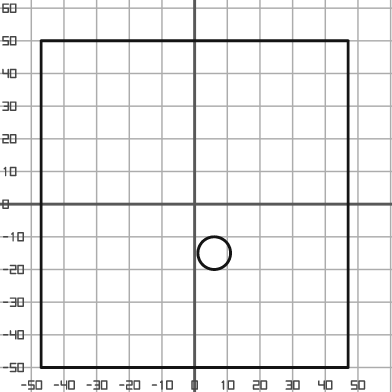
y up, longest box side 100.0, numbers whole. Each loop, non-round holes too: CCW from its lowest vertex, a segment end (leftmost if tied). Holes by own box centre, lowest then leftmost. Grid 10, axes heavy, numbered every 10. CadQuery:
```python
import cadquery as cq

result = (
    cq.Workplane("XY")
    .moveTo(-47.0, -50.0)
    .lineTo(47.0, -50.0)
    .lineTo(47.0, 50.0)
    .lineTo(-47.0, 50.0)
    .close()
    .moveTo(6.0, -15.0)
    .circle(5.0)
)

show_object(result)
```